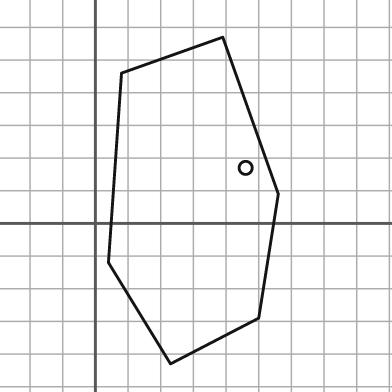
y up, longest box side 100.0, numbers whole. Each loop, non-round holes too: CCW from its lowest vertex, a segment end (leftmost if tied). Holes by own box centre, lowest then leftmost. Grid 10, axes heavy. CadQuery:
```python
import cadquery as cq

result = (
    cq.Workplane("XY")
    .moveTo(23.0, -43.0)
    .lineTo(50.0, -29.0)
    .lineTo(56.0, 9.0)
    .lineTo(39.0, 57.0)
    .lineTo(8.0, 46.0)
    .lineTo(4.0, -12.0)
    .close()
    .moveTo(46.0, 17.0)
    .circle(2.0)
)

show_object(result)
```